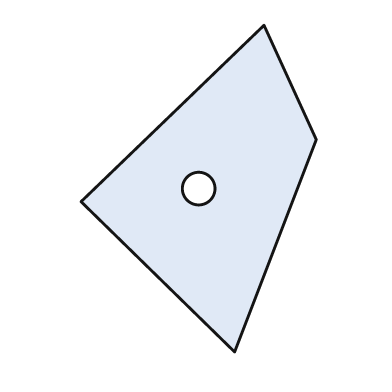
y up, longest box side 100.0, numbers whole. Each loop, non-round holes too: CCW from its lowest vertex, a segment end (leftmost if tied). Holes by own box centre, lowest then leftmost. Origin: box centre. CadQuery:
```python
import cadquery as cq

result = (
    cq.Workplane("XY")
    .moveTo(11.0, -50.0)
    .lineTo(36.0, 15.0)
    .lineTo(20.0, 50.0)
    .lineTo(-36.0, -4.0)
    .close()
    .moveTo(0.0, 0.0)
    .circle(5.0)
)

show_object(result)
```